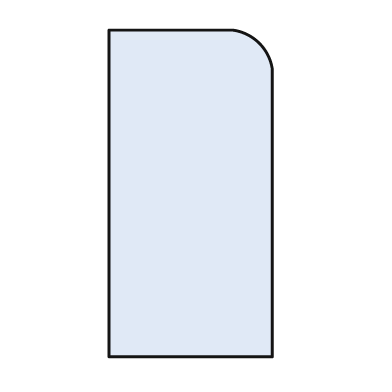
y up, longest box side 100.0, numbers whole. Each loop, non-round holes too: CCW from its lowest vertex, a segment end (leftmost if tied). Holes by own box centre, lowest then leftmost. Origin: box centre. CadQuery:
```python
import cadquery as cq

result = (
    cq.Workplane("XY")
    .moveTo(-25.0, -50.0)
    .lineTo(25.0, -50.0)
    .lineTo(25.0, 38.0)
    .threePointArc((21.0, 46.0), (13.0, 50.0))
    .lineTo(-25.0, 50.0)
    .close()
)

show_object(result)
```